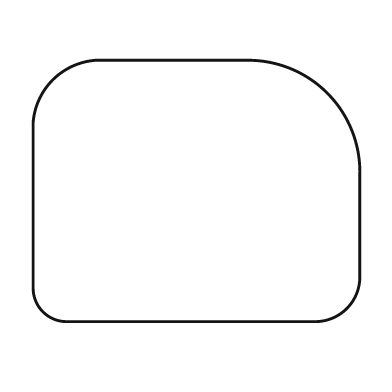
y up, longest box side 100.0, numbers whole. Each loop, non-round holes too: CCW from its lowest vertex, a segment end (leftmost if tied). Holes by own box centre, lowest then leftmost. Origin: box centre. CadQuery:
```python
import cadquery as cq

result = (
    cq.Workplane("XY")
    .moveTo(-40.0, -40.0)
    .lineTo(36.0, -40.0)
    .threePointArc((46.0, -36.0), (50.0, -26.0))
    .lineTo(50.0, 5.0)
    .threePointArc((40.0, 30.0), (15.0, 40.0))
    .lineTo(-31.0, 40.0)
    .threePointArc((-44.0, 34.0), (-50.0, 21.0))
    .lineTo(-50.0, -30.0)
    .threePointArc((-47.0, -37.0), (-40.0, -40.0))
    .close()
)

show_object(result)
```